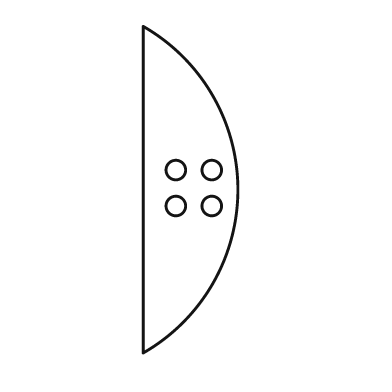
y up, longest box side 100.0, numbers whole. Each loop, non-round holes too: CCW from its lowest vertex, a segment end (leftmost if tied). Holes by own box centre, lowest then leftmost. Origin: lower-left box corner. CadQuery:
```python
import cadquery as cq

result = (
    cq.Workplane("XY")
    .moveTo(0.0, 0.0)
    .threePointArc((29.0, 50.0), (0.0, 100.0))
    .close()
    .moveTo(10.0, 45.0)
    .circle(3.0)
    .moveTo(21.0, 45.0)
    .circle(3.0)
    .moveTo(10.0, 56.0)
    .circle(3.0)
    .moveTo(21.0, 56.0)
    .circle(3.0)
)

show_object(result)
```